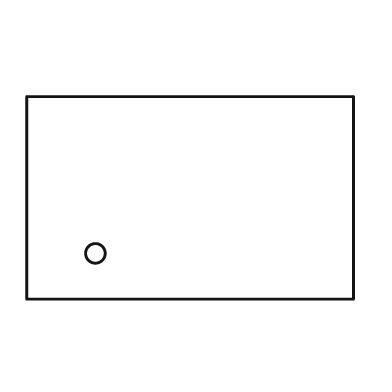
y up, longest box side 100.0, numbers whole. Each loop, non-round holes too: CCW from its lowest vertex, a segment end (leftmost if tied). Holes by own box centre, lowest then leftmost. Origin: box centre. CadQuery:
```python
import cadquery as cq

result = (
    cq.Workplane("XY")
    .moveTo(-50.0, -31.0)
    .lineTo(50.0, -31.0)
    .lineTo(50.0, 31.0)
    .lineTo(-50.0, 31.0)
    .close()
    .moveTo(-29.0, -17.0)
    .circle(3.0)
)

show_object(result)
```